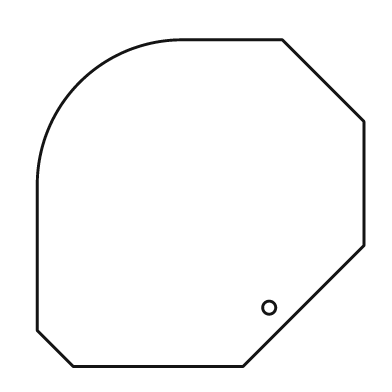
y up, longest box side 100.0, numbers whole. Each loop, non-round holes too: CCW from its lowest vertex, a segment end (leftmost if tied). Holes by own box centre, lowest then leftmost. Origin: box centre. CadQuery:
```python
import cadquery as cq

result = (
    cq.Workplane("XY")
    .moveTo(-39.0, -50.0)
    .lineTo(13.0, -50.0)
    .lineTo(50.0, -13.0)
    .lineTo(50.0, 25.0)
    .lineTo(25.0, 50.0)
    .lineTo(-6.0, 50.0)
    .threePointArc((-37.0, 37.0), (-50.0, 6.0))
    .lineTo(-50.0, -39.0)
    .close()
    .moveTo(21.0, -32.0)
    .circle(2.0)
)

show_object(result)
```